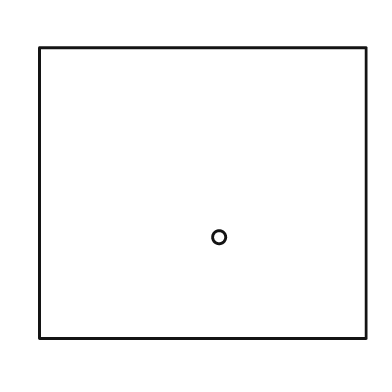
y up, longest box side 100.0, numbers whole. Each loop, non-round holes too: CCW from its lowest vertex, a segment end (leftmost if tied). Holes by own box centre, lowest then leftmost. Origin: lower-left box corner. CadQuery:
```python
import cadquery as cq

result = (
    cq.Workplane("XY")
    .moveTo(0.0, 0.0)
    .lineTo(100.0, 0.0)
    .lineTo(100.0, 89.0)
    .lineTo(0.0, 89.0)
    .close()
    .moveTo(55.0, 31.0)
    .circle(2.0)
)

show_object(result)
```